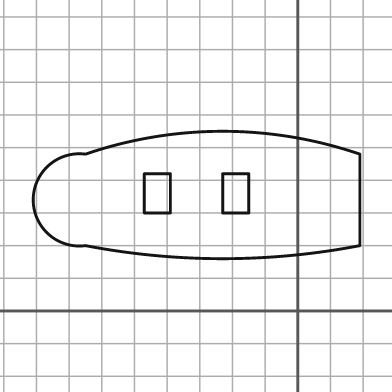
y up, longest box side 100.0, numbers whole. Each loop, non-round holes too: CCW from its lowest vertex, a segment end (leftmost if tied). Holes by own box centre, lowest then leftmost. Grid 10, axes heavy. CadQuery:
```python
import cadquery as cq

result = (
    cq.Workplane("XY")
    .moveTo(-65.0, 20.0)
    .threePointArc((-23.0, 16.0), (19.0, 20.0))
    .lineTo(19.0, 48.0)
    .threePointArc((-23.0, 55.0), (-65.0, 48.0))
    .threePointArc((-81.0, 34.0), (-65.0, 20.0))
    .close()
    .moveTo(-47.0, 30.0)
    .lineTo(-39.0, 30.0)
    .lineTo(-39.0, 42.0)
    .lineTo(-47.0, 42.0)
    .close()
    .moveTo(-23.0, 30.0)
    .lineTo(-15.0, 30.0)
    .lineTo(-15.0, 42.0)
    .lineTo(-23.0, 42.0)
    .close()
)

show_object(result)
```